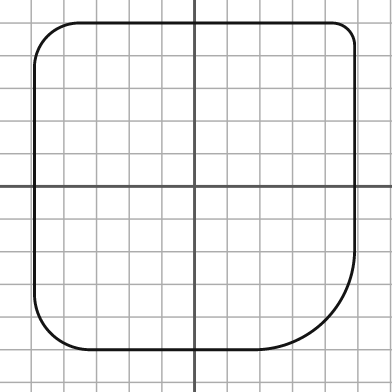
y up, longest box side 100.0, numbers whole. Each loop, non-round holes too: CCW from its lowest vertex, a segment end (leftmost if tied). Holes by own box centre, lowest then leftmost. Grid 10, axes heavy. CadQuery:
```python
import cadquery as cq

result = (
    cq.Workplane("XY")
    .moveTo(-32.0, -50.0)
    .lineTo(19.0, -50.0)
    .threePointArc((40.0, -41.0), (49.0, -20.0))
    .lineTo(49.0, 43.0)
    .threePointArc((47.0, 48.0), (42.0, 50.0))
    .lineTo(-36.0, 50.0)
    .threePointArc((-45.0, 46.0), (-49.0, 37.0))
    .lineTo(-49.0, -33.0)
    .threePointArc((-44.0, -45.0), (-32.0, -50.0))
    .close()
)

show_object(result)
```